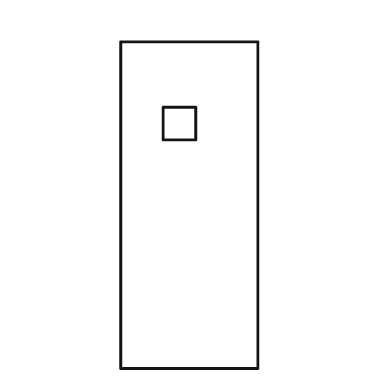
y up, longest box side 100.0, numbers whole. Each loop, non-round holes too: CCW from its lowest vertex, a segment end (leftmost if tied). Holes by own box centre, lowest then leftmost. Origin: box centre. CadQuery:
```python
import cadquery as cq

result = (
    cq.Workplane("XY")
    .moveTo(-21.0, -50.0)
    .lineTo(21.0, -50.0)
    .lineTo(21.0, 50.0)
    .lineTo(-21.0, 50.0)
    .close()
    .moveTo(-8.0, 20.0)
    .lineTo(2.0, 20.0)
    .lineTo(2.0, 30.0)
    .lineTo(-8.0, 30.0)
    .close()
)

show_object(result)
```